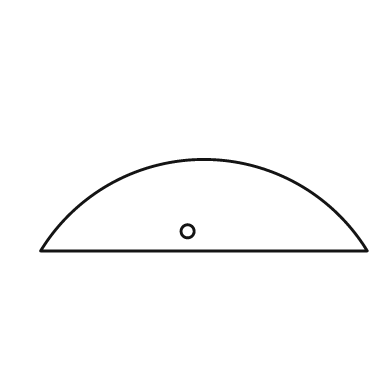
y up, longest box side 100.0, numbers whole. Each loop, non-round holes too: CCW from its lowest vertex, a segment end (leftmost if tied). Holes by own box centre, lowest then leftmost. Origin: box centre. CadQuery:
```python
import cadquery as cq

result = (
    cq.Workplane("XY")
    .moveTo(-50.0, -14.0)
    .lineTo(50.0, -14.0)
    .threePointArc((0.0, 14.0), (-50.0, -14.0))
    .close()
    .moveTo(-5.0, -8.0)
    .circle(2.0)
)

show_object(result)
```